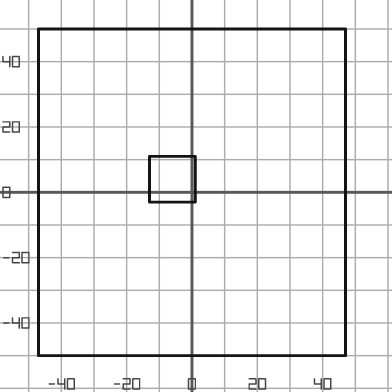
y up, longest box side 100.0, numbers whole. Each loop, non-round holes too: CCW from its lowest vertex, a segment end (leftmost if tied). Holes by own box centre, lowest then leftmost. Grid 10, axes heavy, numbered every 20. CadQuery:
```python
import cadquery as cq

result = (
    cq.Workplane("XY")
    .moveTo(-47.0, -50.0)
    .lineTo(47.0, -50.0)
    .lineTo(47.0, 50.0)
    .lineTo(-47.0, 50.0)
    .close()
    .moveTo(-13.0, -3.0)
    .lineTo(1.0, -3.0)
    .lineTo(1.0, 11.0)
    .lineTo(-13.0, 11.0)
    .close()
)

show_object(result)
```